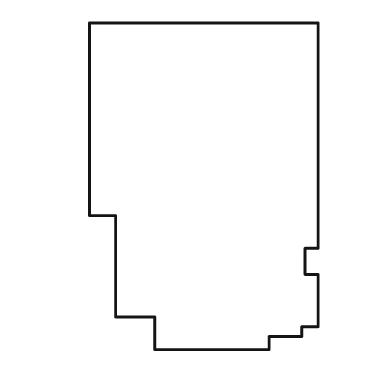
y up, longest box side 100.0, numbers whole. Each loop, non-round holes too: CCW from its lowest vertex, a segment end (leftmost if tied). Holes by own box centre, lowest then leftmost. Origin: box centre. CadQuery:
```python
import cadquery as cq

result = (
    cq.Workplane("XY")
    .moveTo(-15.0, -50.0)
    .lineTo(20.0, -50.0)
    .lineTo(20.0, -46.0)
    .lineTo(30.0, -46.0)
    .lineTo(30.0, -43.0)
    .lineTo(35.0, -43.0)
    .lineTo(35.0, -27.0)
    .lineTo(31.0, -27.0)
    .lineTo(31.0, -19.0)
    .lineTo(35.0, -19.0)
    .lineTo(35.0, 50.0)
    .lineTo(-35.0, 50.0)
    .lineTo(-35.0, -9.0)
    .lineTo(-27.0, -9.0)
    .lineTo(-27.0, -40.0)
    .lineTo(-15.0, -40.0)
    .close()
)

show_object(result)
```